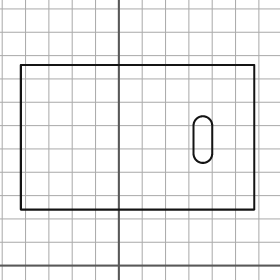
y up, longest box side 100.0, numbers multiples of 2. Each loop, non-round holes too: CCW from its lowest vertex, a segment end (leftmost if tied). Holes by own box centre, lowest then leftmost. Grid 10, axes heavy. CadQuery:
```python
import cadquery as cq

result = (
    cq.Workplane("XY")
    .moveTo(-42.0, 24.0)
    .lineTo(58.0, 24.0)
    .lineTo(58.0, 86.0)
    .lineTo(-42.0, 86.0)
    .close()
    .moveTo(32.0, 48.0)
    .threePointArc((36.0, 44.0), (40.0, 48.0))
    .lineTo(40.0, 60.0)
    .threePointArc((36.0, 64.0), (32.0, 60.0))
    .close()
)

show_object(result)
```